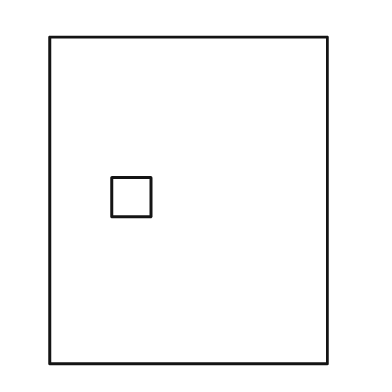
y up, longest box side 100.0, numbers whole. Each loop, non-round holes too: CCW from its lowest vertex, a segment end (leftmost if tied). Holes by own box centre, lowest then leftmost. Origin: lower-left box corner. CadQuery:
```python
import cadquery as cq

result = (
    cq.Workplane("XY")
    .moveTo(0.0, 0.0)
    .lineTo(85.0, 0.0)
    .lineTo(85.0, 100.0)
    .lineTo(0.0, 100.0)
    .close()
    .moveTo(19.0, 45.0)
    .lineTo(31.0, 45.0)
    .lineTo(31.0, 57.0)
    .lineTo(19.0, 57.0)
    .close()
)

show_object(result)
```